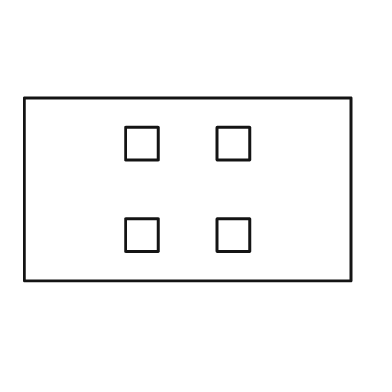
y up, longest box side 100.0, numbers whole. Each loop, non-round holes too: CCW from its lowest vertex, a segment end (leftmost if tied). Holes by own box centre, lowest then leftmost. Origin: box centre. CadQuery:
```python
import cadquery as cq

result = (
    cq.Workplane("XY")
    .moveTo(-50.0, -28.0)
    .lineTo(50.0, -28.0)
    .lineTo(50.0, 28.0)
    .lineTo(-50.0, 28.0)
    .close()
    .moveTo(-19.0, -19.0)
    .lineTo(-9.0, -19.0)
    .lineTo(-9.0, -9.0)
    .lineTo(-19.0, -9.0)
    .close()
    .moveTo(9.0, -19.0)
    .lineTo(19.0, -19.0)
    .lineTo(19.0, -9.0)
    .lineTo(9.0, -9.0)
    .close()
    .moveTo(-19.0, 9.0)
    .lineTo(-9.0, 9.0)
    .lineTo(-9.0, 19.0)
    .lineTo(-19.0, 19.0)
    .close()
    .moveTo(9.0, 9.0)
    .lineTo(19.0, 9.0)
    .lineTo(19.0, 19.0)
    .lineTo(9.0, 19.0)
    .close()
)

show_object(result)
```